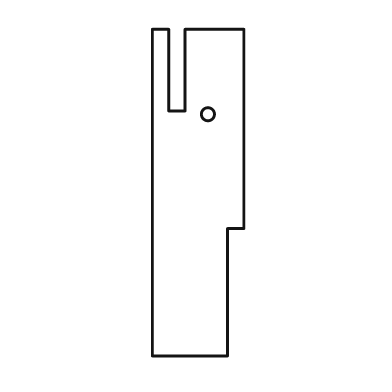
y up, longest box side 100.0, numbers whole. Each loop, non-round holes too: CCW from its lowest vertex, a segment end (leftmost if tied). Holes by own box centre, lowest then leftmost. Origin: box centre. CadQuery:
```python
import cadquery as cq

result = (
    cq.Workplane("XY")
    .moveTo(-14.0, -50.0)
    .lineTo(9.0, -50.0)
    .lineTo(9.0, -11.0)
    .lineTo(14.0, -11.0)
    .lineTo(14.0, 50.0)
    .lineTo(-4.0, 50.0)
    .lineTo(-4.0, 25.0)
    .lineTo(-9.0, 25.0)
    .lineTo(-9.0, 50.0)
    .lineTo(-14.0, 50.0)
    .close()
    .moveTo(3.0, 24.0)
    .circle(2.0)
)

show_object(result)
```